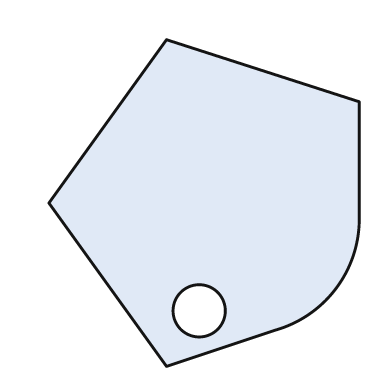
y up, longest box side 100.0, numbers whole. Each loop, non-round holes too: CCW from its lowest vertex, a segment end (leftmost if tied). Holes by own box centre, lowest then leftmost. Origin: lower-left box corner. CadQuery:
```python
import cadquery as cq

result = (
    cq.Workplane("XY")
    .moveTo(36.0, 0.0)
    .lineTo(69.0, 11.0)
    .threePointArc((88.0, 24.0), (95.0, 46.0))
    .lineTo(95.0, 81.0)
    .lineTo(36.0, 100.0)
    .lineTo(0.0, 50.0)
    .close()
    .moveTo(46.0, 17.0)
    .circle(8.0)
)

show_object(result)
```